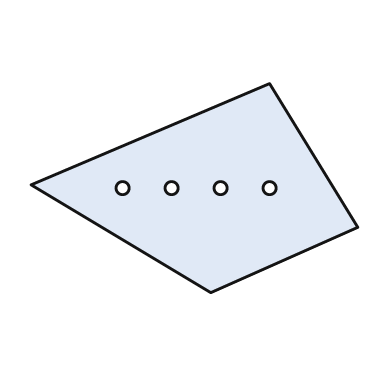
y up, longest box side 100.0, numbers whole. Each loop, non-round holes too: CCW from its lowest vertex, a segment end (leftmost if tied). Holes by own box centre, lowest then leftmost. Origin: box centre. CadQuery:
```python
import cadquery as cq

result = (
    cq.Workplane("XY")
    .moveTo(5.0, -32.0)
    .lineTo(50.0, -12.0)
    .lineTo(23.0, 32.0)
    .lineTo(-50.0, 1.0)
    .close()
    .moveTo(-22.0, 0.0)
    .circle(2.0)
    .moveTo(-7.0, 0.0)
    .circle(2.0)
    .moveTo(8.0, 0.0)
    .circle(2.0)
    .moveTo(23.0, 0.0)
    .circle(2.0)
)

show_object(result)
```